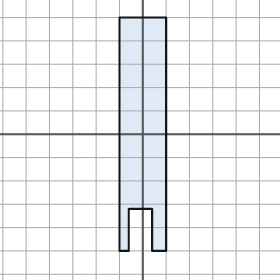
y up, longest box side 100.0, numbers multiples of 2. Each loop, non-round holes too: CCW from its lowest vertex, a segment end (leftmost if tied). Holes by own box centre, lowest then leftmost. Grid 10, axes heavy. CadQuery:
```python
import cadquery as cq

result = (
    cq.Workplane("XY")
    .moveTo(-10.0, -50.0)
    .lineTo(-6.0, -50.0)
    .lineTo(-6.0, -32.0)
    .lineTo(4.0, -32.0)
    .lineTo(4.0, -50.0)
    .lineTo(10.0, -50.0)
    .lineTo(10.0, 50.0)
    .lineTo(-10.0, 50.0)
    .close()
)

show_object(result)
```